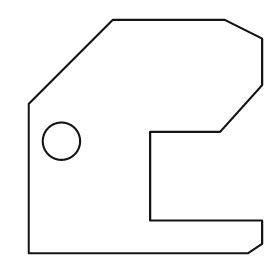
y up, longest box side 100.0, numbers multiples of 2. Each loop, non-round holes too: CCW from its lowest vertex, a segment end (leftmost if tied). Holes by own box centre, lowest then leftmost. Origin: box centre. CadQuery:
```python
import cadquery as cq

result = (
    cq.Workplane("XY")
    .moveTo(-50.0, -50.0)
    .lineTo(44.0, -50.0)
    .lineTo(50.0, -46.0)
    .lineTo(50.0, -36.0)
    .lineTo(2.0, -36.0)
    .lineTo(2.0, 2.0)
    .lineTo(32.0, 2.0)
    .lineTo(50.0, 22.0)
    .lineTo(50.0, 42.0)
    .lineTo(34.0, 50.0)
    .lineTo(-14.0, 50.0)
    .lineTo(-50.0, 14.0)
    .close()
    .moveTo(-36.0, -2.0)
    .circle(8.0)
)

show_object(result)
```